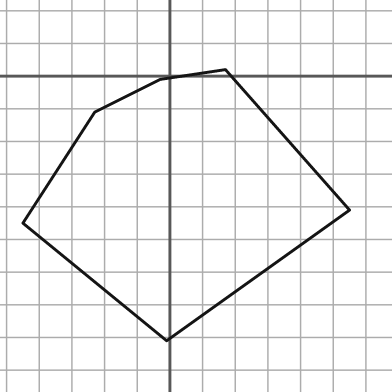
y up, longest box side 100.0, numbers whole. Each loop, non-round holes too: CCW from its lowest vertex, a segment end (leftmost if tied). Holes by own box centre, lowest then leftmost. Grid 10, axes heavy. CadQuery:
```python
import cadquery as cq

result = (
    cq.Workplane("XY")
    .moveTo(-1.0, -81.0)
    .lineTo(55.0, -41.0)
    .lineTo(17.0, 2.0)
    .lineTo(-3.0, -1.0)
    .lineTo(-23.0, -11.0)
    .lineTo(-45.0, -45.0)
    .close()
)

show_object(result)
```